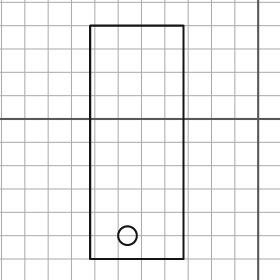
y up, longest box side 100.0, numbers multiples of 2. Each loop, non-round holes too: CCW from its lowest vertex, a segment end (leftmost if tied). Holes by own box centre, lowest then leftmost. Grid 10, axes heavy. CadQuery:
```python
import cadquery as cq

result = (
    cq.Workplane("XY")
    .moveTo(-72.0, -60.0)
    .lineTo(-32.0, -60.0)
    .lineTo(-32.0, 40.0)
    .lineTo(-72.0, 40.0)
    .close()
    .moveTo(-56.0, -50.0)
    .circle(4.0)
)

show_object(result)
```